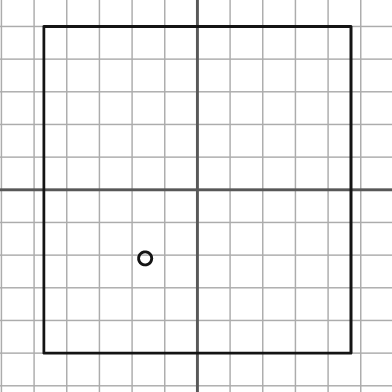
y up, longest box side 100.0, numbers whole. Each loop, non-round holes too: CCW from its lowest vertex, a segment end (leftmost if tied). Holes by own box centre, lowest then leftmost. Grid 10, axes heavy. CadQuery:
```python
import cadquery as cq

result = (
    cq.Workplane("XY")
    .moveTo(-47.0, -50.0)
    .lineTo(47.0, -50.0)
    .lineTo(47.0, 50.0)
    .lineTo(-47.0, 50.0)
    .close()
    .moveTo(-16.0, -21.0)
    .circle(2.0)
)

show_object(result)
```